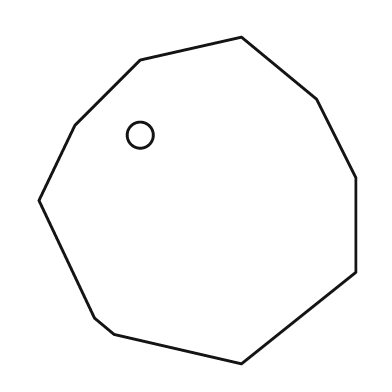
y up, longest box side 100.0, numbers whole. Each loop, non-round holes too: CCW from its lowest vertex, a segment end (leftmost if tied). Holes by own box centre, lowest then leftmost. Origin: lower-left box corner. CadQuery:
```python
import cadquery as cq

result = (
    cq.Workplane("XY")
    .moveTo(62.0, 0.0)
    .lineTo(97.0, 28.0)
    .lineTo(97.0, 57.0)
    .lineTo(85.0, 81.0)
    .lineTo(62.0, 100.0)
    .lineTo(31.0, 93.0)
    .lineTo(11.0, 73.0)
    .lineTo(0.0, 50.0)
    .lineTo(17.0, 14.0)
    .lineTo(23.0, 9.0)
    .close()
    .moveTo(31.0, 70.0)
    .circle(4.0)
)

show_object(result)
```